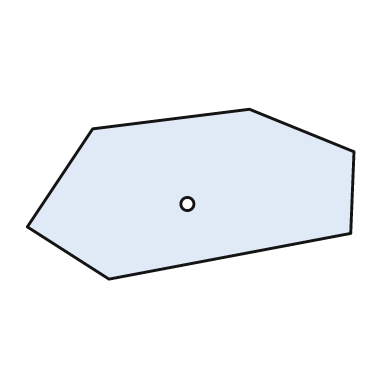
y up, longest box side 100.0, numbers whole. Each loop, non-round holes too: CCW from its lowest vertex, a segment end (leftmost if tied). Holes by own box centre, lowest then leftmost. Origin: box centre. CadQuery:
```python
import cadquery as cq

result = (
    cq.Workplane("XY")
    .moveTo(-25.0, -26.0)
    .lineTo(49.0, -12.0)
    .lineTo(50.0, 13.0)
    .lineTo(18.0, 26.0)
    .lineTo(-30.0, 20.0)
    .lineTo(-50.0, -10.0)
    .close()
    .moveTo(-1.0, -3.0)
    .circle(2.0)
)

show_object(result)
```